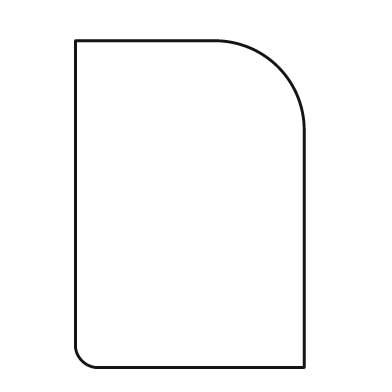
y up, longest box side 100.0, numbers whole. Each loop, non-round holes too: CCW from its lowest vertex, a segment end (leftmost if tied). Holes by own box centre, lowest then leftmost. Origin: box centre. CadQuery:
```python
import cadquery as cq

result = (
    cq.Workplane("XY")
    .moveTo(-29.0, -50.0)
    .lineTo(35.0, -50.0)
    .lineTo(35.0, 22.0)
    .threePointArc((27.0, 42.0), (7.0, 50.0))
    .lineTo(-35.0, 50.0)
    .lineTo(-35.0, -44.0)
    .threePointArc((-33.0, -48.0), (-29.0, -50.0))
    .close()
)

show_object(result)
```